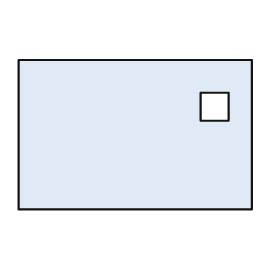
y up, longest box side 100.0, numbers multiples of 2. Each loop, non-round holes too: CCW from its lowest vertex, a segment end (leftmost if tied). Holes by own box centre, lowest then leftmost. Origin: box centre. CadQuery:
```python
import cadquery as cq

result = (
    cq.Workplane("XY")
    .moveTo(-50.0, -32.0)
    .lineTo(50.0, -32.0)
    .lineTo(50.0, 32.0)
    .lineTo(-50.0, 32.0)
    .close()
    .moveTo(28.0, 6.0)
    .lineTo(40.0, 6.0)
    .lineTo(40.0, 18.0)
    .lineTo(28.0, 18.0)
    .close()
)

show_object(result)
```